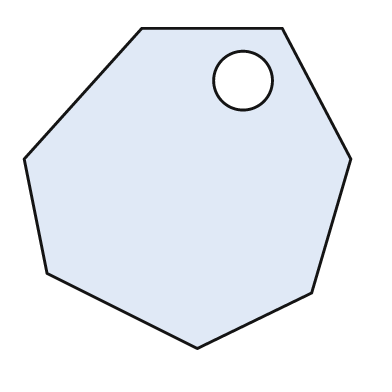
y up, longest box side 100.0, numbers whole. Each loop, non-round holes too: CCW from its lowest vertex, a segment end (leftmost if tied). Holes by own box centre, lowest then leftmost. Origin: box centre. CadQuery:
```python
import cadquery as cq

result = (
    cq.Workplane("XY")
    .moveTo(3.0, -49.0)
    .lineTo(38.0, -32.0)
    .lineTo(50.0, 9.0)
    .lineTo(29.0, 49.0)
    .lineTo(-14.0, 49.0)
    .lineTo(-50.0, 9.0)
    .lineTo(-43.0, -26.0)
    .close()
    .moveTo(17.0, 33.0)
    .circle(9.0)
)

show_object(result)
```